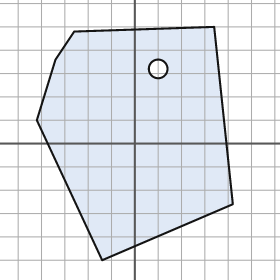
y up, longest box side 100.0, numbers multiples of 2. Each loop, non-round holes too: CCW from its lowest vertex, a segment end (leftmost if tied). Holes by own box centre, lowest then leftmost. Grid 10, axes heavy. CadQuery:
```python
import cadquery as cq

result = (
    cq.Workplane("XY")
    .moveTo(-14.0, -50.0)
    .lineTo(42.0, -26.0)
    .lineTo(34.0, 50.0)
    .lineTo(-26.0, 48.0)
    .lineTo(-34.0, 36.0)
    .lineTo(-42.0, 10.0)
    .close()
    .moveTo(10.0, 32.0)
    .circle(4.0)
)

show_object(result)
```